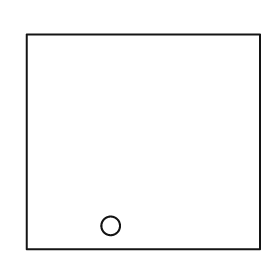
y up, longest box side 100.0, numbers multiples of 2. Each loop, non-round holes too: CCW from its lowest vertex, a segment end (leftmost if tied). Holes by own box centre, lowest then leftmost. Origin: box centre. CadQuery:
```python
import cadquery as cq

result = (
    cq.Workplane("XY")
    .moveTo(-50.0, -46.0)
    .lineTo(50.0, -46.0)
    .lineTo(50.0, 46.0)
    .lineTo(-50.0, 46.0)
    .close()
    .moveTo(-14.0, -36.0)
    .circle(4.0)
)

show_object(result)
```